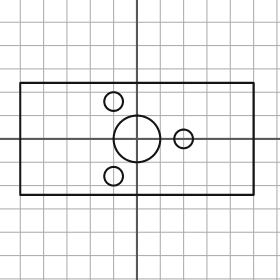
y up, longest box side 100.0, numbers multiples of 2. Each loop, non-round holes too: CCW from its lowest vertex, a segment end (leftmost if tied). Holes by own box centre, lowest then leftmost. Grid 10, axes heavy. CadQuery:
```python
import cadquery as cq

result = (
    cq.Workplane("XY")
    .moveTo(-50.0, -24.0)
    .lineTo(50.0, -24.0)
    .lineTo(50.0, 24.0)
    .lineTo(-50.0, 24.0)
    .close()
    .moveTo(-10.0, -16.0)
    .circle(4.0)
    .moveTo(0.0, 0.0)
    .circle(10.0)
    .moveTo(20.0, 0.0)
    .circle(4.0)
    .moveTo(-10.0, 16.0)
    .circle(4.0)
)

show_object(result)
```